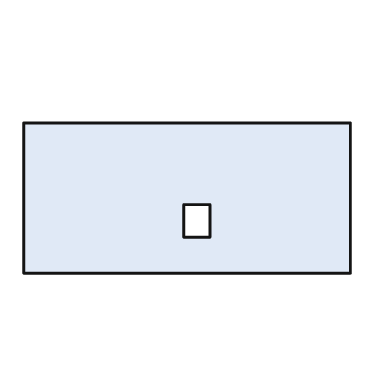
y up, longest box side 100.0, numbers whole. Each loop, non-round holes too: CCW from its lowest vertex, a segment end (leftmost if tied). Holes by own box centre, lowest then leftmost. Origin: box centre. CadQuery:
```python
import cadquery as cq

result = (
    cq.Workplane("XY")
    .moveTo(-50.0, -23.0)
    .lineTo(50.0, -23.0)
    .lineTo(50.0, 23.0)
    .lineTo(-50.0, 23.0)
    .close()
    .moveTo(-1.0, -12.0)
    .lineTo(7.0, -12.0)
    .lineTo(7.0, -2.0)
    .lineTo(-1.0, -2.0)
    .close()
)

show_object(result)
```